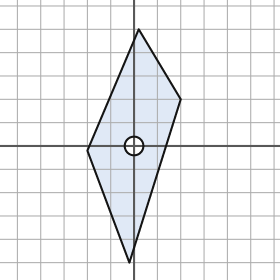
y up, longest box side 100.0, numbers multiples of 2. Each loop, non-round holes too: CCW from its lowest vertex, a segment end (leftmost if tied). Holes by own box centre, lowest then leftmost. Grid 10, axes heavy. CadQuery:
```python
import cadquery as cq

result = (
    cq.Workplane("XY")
    .moveTo(-2.0, -50.0)
    .lineTo(20.0, 20.0)
    .lineTo(2.0, 50.0)
    .lineTo(-20.0, -2.0)
    .close()
    .moveTo(0.0, 0.0)
    .circle(4.0)
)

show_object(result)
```